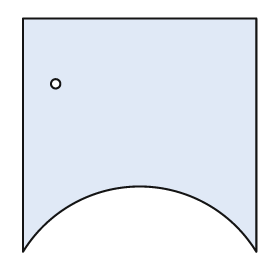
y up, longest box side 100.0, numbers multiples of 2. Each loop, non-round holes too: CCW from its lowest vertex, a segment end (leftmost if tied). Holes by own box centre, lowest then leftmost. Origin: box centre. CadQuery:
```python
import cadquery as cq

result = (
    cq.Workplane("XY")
    .moveTo(-50.0, -50.0)
    .threePointArc((0.0, -22.0), (50.0, -50.0))
    .lineTo(50.0, 50.0)
    .lineTo(-50.0, 50.0)
    .close()
    .moveTo(-36.0, 22.0)
    .circle(2.0)
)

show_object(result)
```